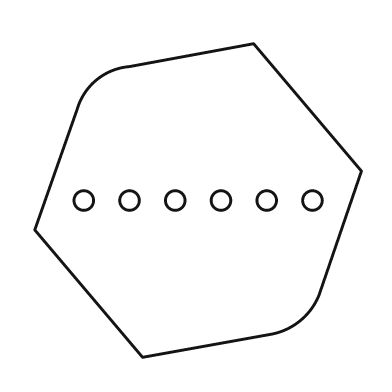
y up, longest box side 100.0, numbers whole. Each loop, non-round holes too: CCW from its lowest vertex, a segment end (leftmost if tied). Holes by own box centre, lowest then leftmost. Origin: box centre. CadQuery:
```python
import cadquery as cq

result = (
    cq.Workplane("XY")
    .moveTo(-17.0, -48.0)
    .lineTo(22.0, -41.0)
    .threePointArc((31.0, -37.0), (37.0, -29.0))
    .lineTo(50.0, 9.0)
    .lineTo(17.0, 48.0)
    .lineTo(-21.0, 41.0)
    .threePointArc((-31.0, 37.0), (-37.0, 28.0))
    .lineTo(-50.0, -9.0)
    .close()
    .moveTo(-35.0, 0.0)
    .circle(3.0)
    .moveTo(-21.0, 0.0)
    .circle(3.0)
    .moveTo(-7.0, 0.0)
    .circle(3.0)
    .moveTo(7.0, 0.0)
    .circle(3.0)
    .moveTo(21.0, 0.0)
    .circle(3.0)
    .moveTo(35.0, 0.0)
    .circle(3.0)
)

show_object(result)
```